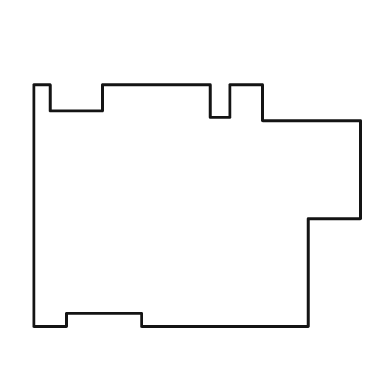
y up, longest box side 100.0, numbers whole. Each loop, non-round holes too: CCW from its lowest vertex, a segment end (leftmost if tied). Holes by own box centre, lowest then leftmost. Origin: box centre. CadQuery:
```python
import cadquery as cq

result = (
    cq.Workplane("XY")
    .moveTo(-50.0, -37.0)
    .lineTo(-40.0, -37.0)
    .lineTo(-40.0, -33.0)
    .lineTo(-17.0, -33.0)
    .lineTo(-17.0, -37.0)
    .lineTo(34.0, -37.0)
    .lineTo(34.0, -4.0)
    .lineTo(50.0, -4.0)
    .lineTo(50.0, 26.0)
    .lineTo(20.0, 26.0)
    .lineTo(20.0, 37.0)
    .lineTo(10.0, 37.0)
    .lineTo(10.0, 27.0)
    .lineTo(4.0, 27.0)
    .lineTo(4.0, 37.0)
    .lineTo(-29.0, 37.0)
    .lineTo(-29.0, 29.0)
    .lineTo(-45.0, 29.0)
    .lineTo(-45.0, 37.0)
    .lineTo(-50.0, 37.0)
    .close()
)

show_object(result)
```